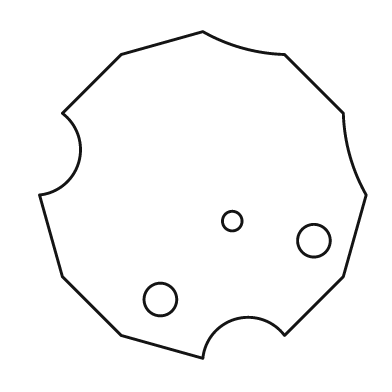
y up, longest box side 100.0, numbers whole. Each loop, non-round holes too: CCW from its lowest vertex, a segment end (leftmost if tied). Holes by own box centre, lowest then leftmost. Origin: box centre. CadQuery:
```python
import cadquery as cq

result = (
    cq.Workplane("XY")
    .moveTo(0.0, -50.0)
    .threePointArc((10.0, -38.0), (25.0, -43.0))
    .lineTo(43.0, -25.0)
    .lineTo(50.0, 0.0)
    .threePointArc((45.0, 12.0), (43.0, 25.0))
    .lineTo(25.0, 43.0)
    .threePointArc((12.0, 45.0), (0.0, 50.0))
    .lineTo(-25.0, 43.0)
    .lineTo(-43.0, 25.0)
    .threePointArc((-38.0, 10.0), (-50.0, 0.0))
    .lineTo(-43.0, -25.0)
    .lineTo(-25.0, -43.0)
    .close()
    .moveTo(-13.0, -32.0)
    .circle(5.0)
    .moveTo(34.0, -14.0)
    .circle(5.0)
    .moveTo(9.0, -8.0)
    .circle(3.0)
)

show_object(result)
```